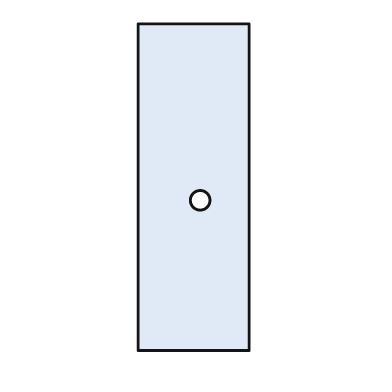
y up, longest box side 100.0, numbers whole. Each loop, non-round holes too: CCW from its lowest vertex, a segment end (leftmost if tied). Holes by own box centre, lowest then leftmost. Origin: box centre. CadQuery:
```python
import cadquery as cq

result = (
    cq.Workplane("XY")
    .moveTo(-17.0, -50.0)
    .lineTo(17.0, -50.0)
    .lineTo(17.0, 50.0)
    .lineTo(-17.0, 50.0)
    .close()
    .moveTo(2.0, -4.0)
    .circle(3.0)
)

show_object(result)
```